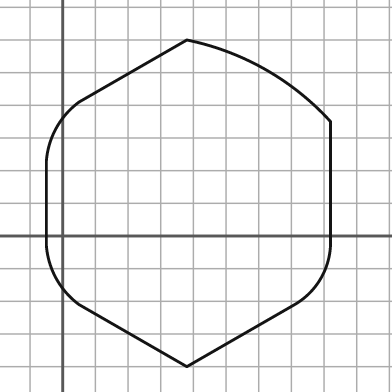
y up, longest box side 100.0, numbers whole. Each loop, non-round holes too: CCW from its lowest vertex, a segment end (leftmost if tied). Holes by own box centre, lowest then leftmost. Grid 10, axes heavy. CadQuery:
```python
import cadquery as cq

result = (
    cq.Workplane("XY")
    .moveTo(38.0, -40.0)
    .lineTo(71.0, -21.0)
    .threePointArc((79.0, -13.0), (82.0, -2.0))
    .lineTo(82.0, 35.0)
    .threePointArc((62.0, 51.0), (38.0, 60.0))
    .lineTo(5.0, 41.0)
    .threePointArc((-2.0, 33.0), (-5.0, 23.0))
    .lineTo(-5.0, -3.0)
    .threePointArc((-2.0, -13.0), (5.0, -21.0))
    .close()
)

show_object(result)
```